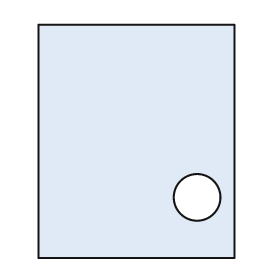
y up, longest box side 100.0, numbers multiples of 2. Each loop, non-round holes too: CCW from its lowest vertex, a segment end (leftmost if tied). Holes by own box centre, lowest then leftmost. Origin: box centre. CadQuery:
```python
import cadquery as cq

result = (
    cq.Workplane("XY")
    .moveTo(-42.0, -50.0)
    .lineTo(42.0, -50.0)
    .lineTo(42.0, 50.0)
    .lineTo(-42.0, 50.0)
    .close()
    .moveTo(26.0, -24.0)
    .circle(10.0)
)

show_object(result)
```